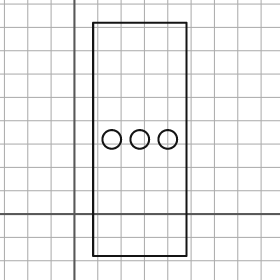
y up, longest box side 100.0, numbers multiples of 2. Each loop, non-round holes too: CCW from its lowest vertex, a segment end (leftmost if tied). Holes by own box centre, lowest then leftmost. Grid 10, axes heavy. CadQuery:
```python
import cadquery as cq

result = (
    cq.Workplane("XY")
    .moveTo(8.0, -18.0)
    .lineTo(48.0, -18.0)
    .lineTo(48.0, 82.0)
    .lineTo(8.0, 82.0)
    .close()
    .moveTo(16.0, 32.0)
    .circle(4.0)
    .moveTo(28.0, 32.0)
    .circle(4.0)
    .moveTo(40.0, 32.0)
    .circle(4.0)
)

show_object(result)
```